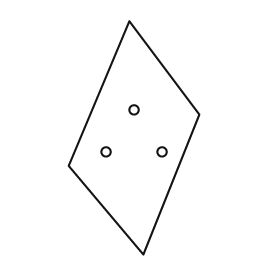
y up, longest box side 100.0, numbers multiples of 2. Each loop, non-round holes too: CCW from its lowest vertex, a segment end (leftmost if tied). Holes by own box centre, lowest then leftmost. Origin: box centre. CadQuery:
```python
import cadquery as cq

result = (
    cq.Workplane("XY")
    .moveTo(4.0, -50.0)
    .lineTo(28.0, 10.0)
    .lineTo(-2.0, 50.0)
    .lineTo(-28.0, -12.0)
    .close()
    .moveTo(-12.0, -6.0)
    .circle(2.0)
    .moveTo(12.0, -6.0)
    .circle(2.0)
    .moveTo(0.0, 12.0)
    .circle(2.0)
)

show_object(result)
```